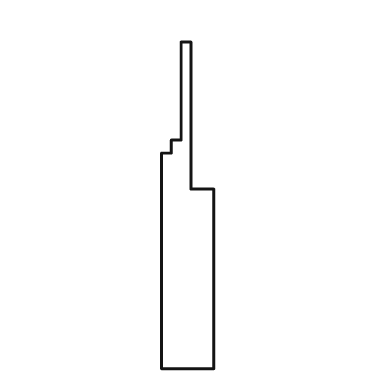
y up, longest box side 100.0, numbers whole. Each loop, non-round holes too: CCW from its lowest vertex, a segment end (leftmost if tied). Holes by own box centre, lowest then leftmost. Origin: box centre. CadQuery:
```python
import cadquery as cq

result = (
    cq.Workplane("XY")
    .moveTo(-8.0, -50.0)
    .lineTo(8.0, -50.0)
    .lineTo(8.0, 5.0)
    .lineTo(1.0, 5.0)
    .lineTo(1.0, 50.0)
    .lineTo(-2.0, 50.0)
    .lineTo(-2.0, 20.0)
    .lineTo(-5.0, 20.0)
    .lineTo(-5.0, 16.0)
    .lineTo(-8.0, 16.0)
    .close()
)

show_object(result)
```